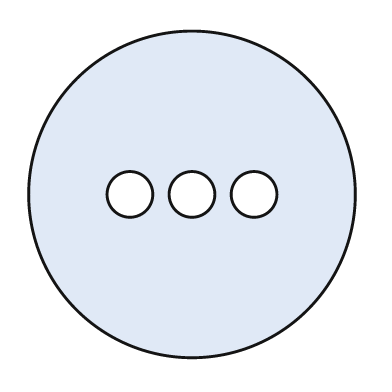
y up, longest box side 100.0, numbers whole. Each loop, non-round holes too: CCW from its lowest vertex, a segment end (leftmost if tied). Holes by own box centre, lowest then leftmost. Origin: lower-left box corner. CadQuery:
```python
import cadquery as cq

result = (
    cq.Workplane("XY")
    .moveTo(50.0, 50.0)
    .circle(50.0)
    .moveTo(31.0, 50.0)
    .circle(7.0)
    .moveTo(50.0, 50.0)
    .circle(7.0)
    .moveTo(69.0, 50.0)
    .circle(7.0)
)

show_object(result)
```